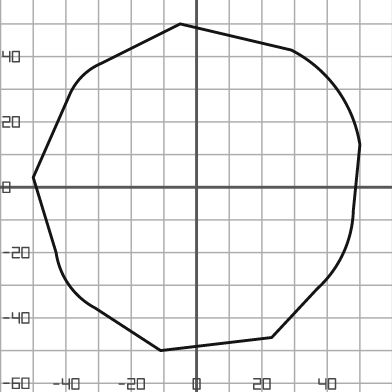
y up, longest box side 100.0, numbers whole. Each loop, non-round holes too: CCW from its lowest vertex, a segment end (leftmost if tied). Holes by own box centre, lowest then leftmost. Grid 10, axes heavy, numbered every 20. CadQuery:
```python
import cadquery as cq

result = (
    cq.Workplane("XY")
    .moveTo(-11.0, -50.0)
    .lineTo(23.0, -46.0)
    .lineTo(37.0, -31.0)
    .threePointArc((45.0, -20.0), (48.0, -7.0))
    .lineTo(50.0, 13.0)
    .threePointArc((43.0, 30.0), (29.0, 42.0))
    .lineTo(-5.0, 50.0)
    .lineTo(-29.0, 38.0)
    .threePointArc((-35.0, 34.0), (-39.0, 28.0))
    .lineTo(-50.0, 3.0)
    .lineTo(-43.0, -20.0)
    .threePointArc((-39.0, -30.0), (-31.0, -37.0))
    .close()
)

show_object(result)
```